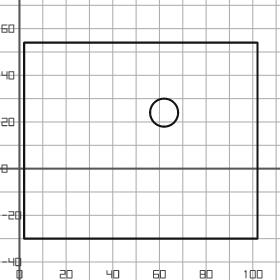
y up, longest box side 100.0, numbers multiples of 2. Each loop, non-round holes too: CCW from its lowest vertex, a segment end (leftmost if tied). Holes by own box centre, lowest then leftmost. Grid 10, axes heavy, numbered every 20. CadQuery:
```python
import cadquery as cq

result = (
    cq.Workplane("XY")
    .moveTo(2.0, -30.0)
    .lineTo(102.0, -30.0)
    .lineTo(102.0, 54.0)
    .lineTo(2.0, 54.0)
    .close()
    .moveTo(62.0, 24.0)
    .circle(6.0)
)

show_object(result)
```